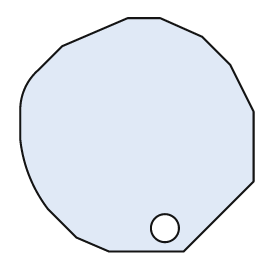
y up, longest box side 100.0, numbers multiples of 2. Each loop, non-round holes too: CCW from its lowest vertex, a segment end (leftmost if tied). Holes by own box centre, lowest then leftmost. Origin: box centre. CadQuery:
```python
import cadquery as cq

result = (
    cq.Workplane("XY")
    .moveTo(-12.0, -50.0)
    .lineTo(20.0, -50.0)
    .lineTo(50.0, -20.0)
    .lineTo(50.0, 10.0)
    .lineTo(40.0, 30.0)
    .lineTo(28.0, 42.0)
    .lineTo(10.0, 50.0)
    .lineTo(-4.0, 50.0)
    .lineTo(-32.0, 38.0)
    .lineTo(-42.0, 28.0)
    .threePointArc((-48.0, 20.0), (-50.0, 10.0))
    .lineTo(-50.0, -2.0)
    .threePointArc((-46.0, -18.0), (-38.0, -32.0))
    .lineTo(-26.0, -44.0)
    .close()
    .moveTo(12.0, -40.0)
    .circle(6.0)
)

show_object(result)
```